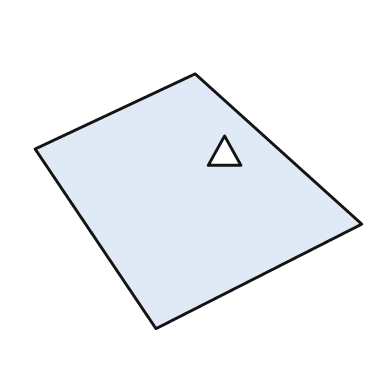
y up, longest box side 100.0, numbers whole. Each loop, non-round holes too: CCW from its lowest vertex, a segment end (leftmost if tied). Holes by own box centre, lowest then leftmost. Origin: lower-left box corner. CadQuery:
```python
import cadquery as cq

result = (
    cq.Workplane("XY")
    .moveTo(37.0, 0.0)
    .lineTo(100.0, 32.0)
    .lineTo(49.0, 78.0)
    .lineTo(0.0, 55.0)
    .close()
    .moveTo(53.0, 50.0)
    .lineTo(63.0, 50.0)
    .lineTo(58.0, 59.0)
    .close()
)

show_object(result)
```